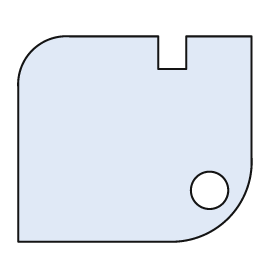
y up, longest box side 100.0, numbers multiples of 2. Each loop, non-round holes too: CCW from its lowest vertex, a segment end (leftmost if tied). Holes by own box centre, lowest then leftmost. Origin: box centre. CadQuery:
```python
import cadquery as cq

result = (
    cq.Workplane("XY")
    .moveTo(-50.0, -44.0)
    .lineTo(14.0, -44.0)
    .threePointArc((40.0, -34.0), (50.0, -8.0))
    .lineTo(50.0, 44.0)
    .lineTo(22.0, 44.0)
    .lineTo(22.0, 30.0)
    .lineTo(10.0, 30.0)
    .lineTo(10.0, 44.0)
    .lineTo(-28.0, 44.0)
    .threePointArc((-44.0, 38.0), (-50.0, 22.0))
    .close()
    .moveTo(32.0, -22.0)
    .circle(8.0)
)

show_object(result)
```